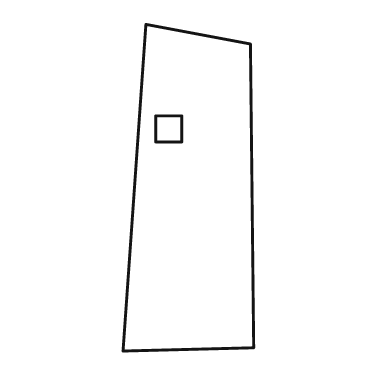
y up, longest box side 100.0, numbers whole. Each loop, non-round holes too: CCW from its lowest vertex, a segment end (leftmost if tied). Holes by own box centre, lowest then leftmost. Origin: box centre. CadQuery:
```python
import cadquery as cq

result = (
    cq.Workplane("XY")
    .moveTo(-20.0, -50.0)
    .lineTo(20.0, -49.0)
    .lineTo(19.0, 44.0)
    .lineTo(-13.0, 50.0)
    .close()
    .moveTo(-10.0, 14.0)
    .lineTo(-2.0, 14.0)
    .lineTo(-2.0, 22.0)
    .lineTo(-10.0, 22.0)
    .close()
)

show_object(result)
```